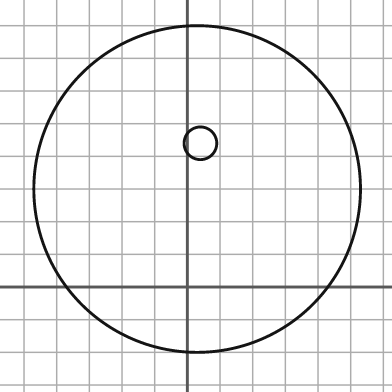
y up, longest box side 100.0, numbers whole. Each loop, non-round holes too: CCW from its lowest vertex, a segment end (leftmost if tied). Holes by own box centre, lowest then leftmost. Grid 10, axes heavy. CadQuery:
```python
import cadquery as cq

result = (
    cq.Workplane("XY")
    .moveTo(3.0, 30.0)
    .circle(50.0)
    .moveTo(4.0, 44.0)
    .circle(5.0)
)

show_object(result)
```